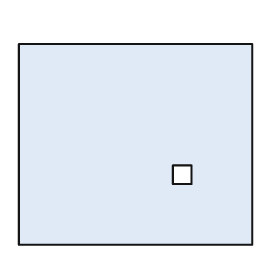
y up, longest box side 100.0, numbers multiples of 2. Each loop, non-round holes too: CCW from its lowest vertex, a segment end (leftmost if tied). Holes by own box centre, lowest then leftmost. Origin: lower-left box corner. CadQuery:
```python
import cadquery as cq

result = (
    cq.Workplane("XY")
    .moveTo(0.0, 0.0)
    .lineTo(100.0, 0.0)
    .lineTo(100.0, 86.0)
    .lineTo(0.0, 86.0)
    .close()
    .moveTo(66.0, 26.0)
    .lineTo(74.0, 26.0)
    .lineTo(74.0, 34.0)
    .lineTo(66.0, 34.0)
    .close()
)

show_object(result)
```